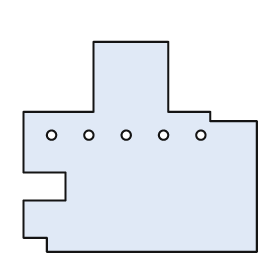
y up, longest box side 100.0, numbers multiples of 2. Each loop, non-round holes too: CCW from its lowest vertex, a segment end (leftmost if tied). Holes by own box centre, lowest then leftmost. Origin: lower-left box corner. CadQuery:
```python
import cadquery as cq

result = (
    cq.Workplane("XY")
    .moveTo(10.0, 0.0)
    .lineTo(100.0, 0.0)
    .lineTo(100.0, 56.0)
    .lineTo(80.0, 56.0)
    .lineTo(80.0, 60.0)
    .lineTo(62.0, 60.0)
    .lineTo(62.0, 90.0)
    .lineTo(30.0, 90.0)
    .lineTo(30.0, 60.0)
    .lineTo(0.0, 60.0)
    .lineTo(0.0, 34.0)
    .lineTo(18.0, 34.0)
    .lineTo(18.0, 22.0)
    .lineTo(0.0, 22.0)
    .lineTo(0.0, 6.0)
    .lineTo(10.0, 6.0)
    .close()
    .moveTo(12.0, 50.0)
    .circle(2.0)
    .moveTo(28.0, 50.0)
    .circle(2.0)
    .moveTo(44.0, 50.0)
    .circle(2.0)
    .moveTo(60.0, 50.0)
    .circle(2.0)
    .moveTo(76.0, 50.0)
    .circle(2.0)
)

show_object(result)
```